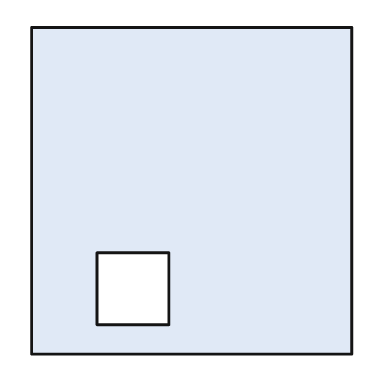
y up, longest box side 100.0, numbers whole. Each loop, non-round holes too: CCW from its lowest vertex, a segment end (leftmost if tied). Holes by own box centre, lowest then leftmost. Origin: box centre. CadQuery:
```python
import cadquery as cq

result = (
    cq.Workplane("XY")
    .moveTo(-49.0, -50.0)
    .lineTo(49.0, -50.0)
    .lineTo(49.0, 50.0)
    .lineTo(-49.0, 50.0)
    .close()
    .moveTo(-29.0, -41.0)
    .lineTo(-7.0, -41.0)
    .lineTo(-7.0, -19.0)
    .lineTo(-29.0, -19.0)
    .close()
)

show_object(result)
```